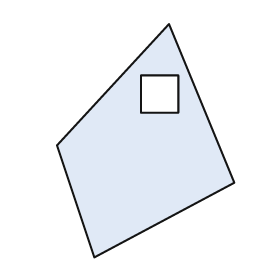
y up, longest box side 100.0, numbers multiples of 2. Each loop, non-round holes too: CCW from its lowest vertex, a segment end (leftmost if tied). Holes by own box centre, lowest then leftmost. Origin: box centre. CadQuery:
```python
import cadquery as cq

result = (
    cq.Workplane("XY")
    .moveTo(-22.0, -50.0)
    .lineTo(38.0, -18.0)
    .lineTo(10.0, 50.0)
    .lineTo(-38.0, -2.0)
    .close()
    .moveTo(-2.0, 12.0)
    .lineTo(14.0, 12.0)
    .lineTo(14.0, 28.0)
    .lineTo(-2.0, 28.0)
    .close()
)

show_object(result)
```